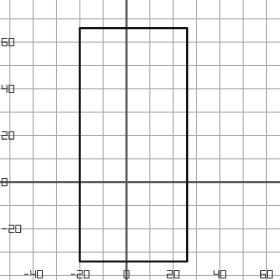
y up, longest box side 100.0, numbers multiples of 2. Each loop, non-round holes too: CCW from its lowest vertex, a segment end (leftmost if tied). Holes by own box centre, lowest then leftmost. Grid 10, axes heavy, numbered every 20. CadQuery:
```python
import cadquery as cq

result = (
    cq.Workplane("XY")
    .moveTo(-20.0, -34.0)
    .lineTo(26.0, -34.0)
    .lineTo(26.0, 66.0)
    .lineTo(-20.0, 66.0)
    .close()
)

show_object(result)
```